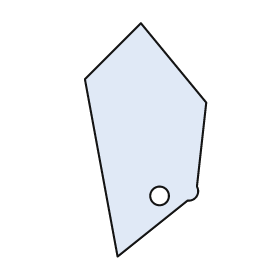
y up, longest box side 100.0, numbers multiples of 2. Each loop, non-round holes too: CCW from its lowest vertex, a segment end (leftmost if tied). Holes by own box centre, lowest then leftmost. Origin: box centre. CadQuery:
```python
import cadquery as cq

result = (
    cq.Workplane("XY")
    .moveTo(-12.0, -50.0)
    .lineTo(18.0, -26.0)
    .threePointArc((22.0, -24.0), (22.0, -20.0))
    .lineTo(26.0, 16.0)
    .lineTo(-2.0, 50.0)
    .lineTo(-26.0, 26.0)
    .close()
    .moveTo(6.0, -24.0)
    .circle(4.0)
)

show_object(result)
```